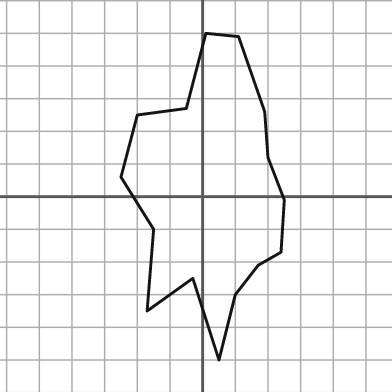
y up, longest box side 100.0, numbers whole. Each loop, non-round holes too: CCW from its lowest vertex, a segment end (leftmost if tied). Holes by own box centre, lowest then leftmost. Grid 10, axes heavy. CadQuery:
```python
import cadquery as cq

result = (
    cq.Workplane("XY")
    .moveTo(5.0, -50.0)
    .lineTo(10.0, -30.0)
    .lineTo(17.0, -21.0)
    .lineTo(24.0, -17.0)
    .lineTo(25.0, -1.0)
    .lineTo(20.0, 12.0)
    .lineTo(19.0, 26.0)
    .lineTo(11.0, 49.0)
    .lineTo(1.0, 50.0)
    .lineTo(-5.0, 27.0)
    .lineTo(-20.0, 25.0)
    .lineTo(-25.0, 6.0)
    .lineTo(-15.0, -10.0)
    .lineTo(-17.0, -35.0)
    .lineTo(-3.0, -25.0)
    .close()
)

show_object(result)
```